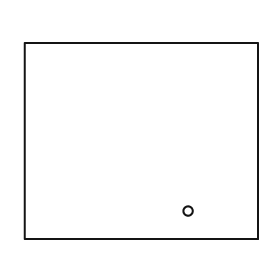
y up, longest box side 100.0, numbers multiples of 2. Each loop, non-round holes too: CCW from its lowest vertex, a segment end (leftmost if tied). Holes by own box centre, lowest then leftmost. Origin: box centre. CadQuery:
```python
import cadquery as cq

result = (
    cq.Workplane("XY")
    .moveTo(-50.0, -42.0)
    .lineTo(50.0, -42.0)
    .lineTo(50.0, 42.0)
    .lineTo(-50.0, 42.0)
    .close()
    .moveTo(20.0, -30.0)
    .circle(2.0)
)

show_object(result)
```